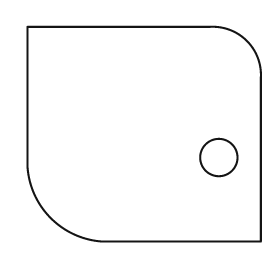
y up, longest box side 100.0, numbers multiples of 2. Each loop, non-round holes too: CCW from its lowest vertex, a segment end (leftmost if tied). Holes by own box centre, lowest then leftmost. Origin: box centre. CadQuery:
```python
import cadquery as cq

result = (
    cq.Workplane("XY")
    .moveTo(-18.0, -46.0)
    .lineTo(50.0, -46.0)
    .lineTo(50.0, 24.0)
    .threePointArc((44.0, 40.0), (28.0, 46.0))
    .lineTo(-50.0, 46.0)
    .lineTo(-50.0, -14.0)
    .threePointArc((-40.0, -36.0), (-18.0, -46.0))
    .close()
    .moveTo(32.0, -10.0)
    .circle(8.0)
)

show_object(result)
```